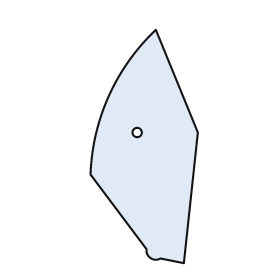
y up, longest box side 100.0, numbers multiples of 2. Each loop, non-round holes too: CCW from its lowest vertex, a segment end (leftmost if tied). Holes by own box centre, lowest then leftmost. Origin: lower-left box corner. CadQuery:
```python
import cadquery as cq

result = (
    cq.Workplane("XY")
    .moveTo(40.0, 0.0)
    .lineTo(46.0, 56.0)
    .lineTo(28.0, 100.0)
    .threePointArc((8.0, 72.0), (0.0, 38.0))
    .lineTo(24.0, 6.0)
    .threePointArc((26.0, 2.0), (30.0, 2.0))
    .close()
    .moveTo(20.0, 56.0)
    .circle(2.0)
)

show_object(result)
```